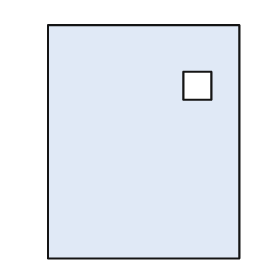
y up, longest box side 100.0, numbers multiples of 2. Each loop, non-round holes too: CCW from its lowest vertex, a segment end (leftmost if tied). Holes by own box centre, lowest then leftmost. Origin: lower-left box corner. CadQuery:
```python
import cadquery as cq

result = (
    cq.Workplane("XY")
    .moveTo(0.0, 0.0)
    .lineTo(82.0, 0.0)
    .lineTo(82.0, 100.0)
    .lineTo(0.0, 100.0)
    .close()
    .moveTo(58.0, 68.0)
    .lineTo(70.0, 68.0)
    .lineTo(70.0, 80.0)
    .lineTo(58.0, 80.0)
    .close()
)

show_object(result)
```